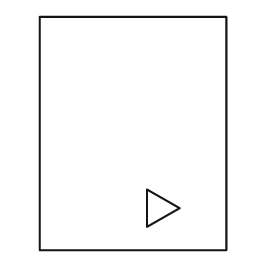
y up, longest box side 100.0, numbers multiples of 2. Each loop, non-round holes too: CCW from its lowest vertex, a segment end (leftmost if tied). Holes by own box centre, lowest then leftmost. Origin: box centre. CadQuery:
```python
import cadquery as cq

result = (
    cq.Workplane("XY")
    .moveTo(-40.0, -50.0)
    .lineTo(40.0, -50.0)
    .lineTo(40.0, 50.0)
    .lineTo(-40.0, 50.0)
    .close()
    .moveTo(6.0, -40.0)
    .lineTo(20.0, -32.0)
    .lineTo(6.0, -24.0)
    .close()
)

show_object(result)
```